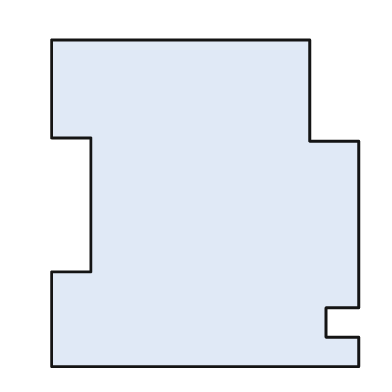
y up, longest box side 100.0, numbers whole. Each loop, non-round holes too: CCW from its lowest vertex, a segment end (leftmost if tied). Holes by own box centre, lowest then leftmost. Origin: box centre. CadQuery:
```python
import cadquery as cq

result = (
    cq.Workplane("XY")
    .moveTo(-47.0, -50.0)
    .lineTo(47.0, -50.0)
    .lineTo(47.0, -41.0)
    .lineTo(37.0, -41.0)
    .lineTo(37.0, -32.0)
    .lineTo(47.0, -32.0)
    .lineTo(47.0, 19.0)
    .lineTo(32.0, 19.0)
    .lineTo(32.0, 50.0)
    .lineTo(-47.0, 50.0)
    .lineTo(-47.0, 20.0)
    .lineTo(-35.0, 20.0)
    .lineTo(-35.0, -21.0)
    .lineTo(-47.0, -21.0)
    .close()
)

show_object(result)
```